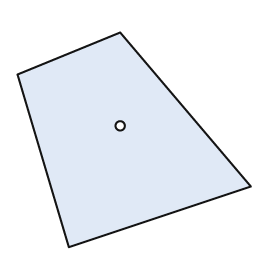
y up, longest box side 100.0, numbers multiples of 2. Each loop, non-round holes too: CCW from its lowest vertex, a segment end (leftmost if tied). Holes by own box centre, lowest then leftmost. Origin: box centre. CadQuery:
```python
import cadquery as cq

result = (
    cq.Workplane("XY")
    .moveTo(-28.0, -46.0)
    .lineTo(50.0, -20.0)
    .lineTo(-6.0, 46.0)
    .lineTo(-50.0, 28.0)
    .close()
    .moveTo(-6.0, 6.0)
    .circle(2.0)
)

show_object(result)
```